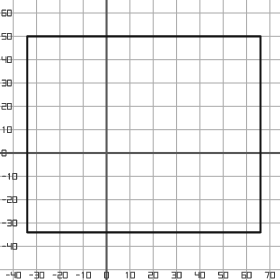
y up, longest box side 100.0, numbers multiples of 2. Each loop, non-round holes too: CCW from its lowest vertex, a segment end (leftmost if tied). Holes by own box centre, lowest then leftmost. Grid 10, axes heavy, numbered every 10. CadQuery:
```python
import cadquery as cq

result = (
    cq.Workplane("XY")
    .moveTo(-34.0, -34.0)
    .lineTo(66.0, -34.0)
    .lineTo(66.0, 50.0)
    .lineTo(-34.0, 50.0)
    .close()
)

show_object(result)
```